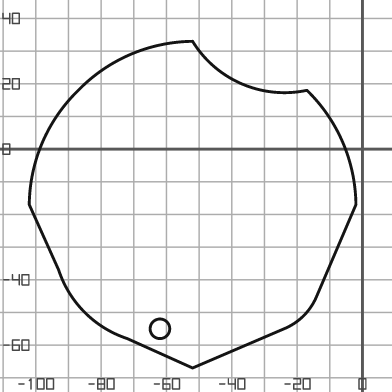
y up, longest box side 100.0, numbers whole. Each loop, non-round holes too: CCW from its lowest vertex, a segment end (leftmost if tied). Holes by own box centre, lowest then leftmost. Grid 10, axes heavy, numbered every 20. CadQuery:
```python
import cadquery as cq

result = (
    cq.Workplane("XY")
    .moveTo(-52.0, -67.0)
    .lineTo(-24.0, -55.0)
    .threePointArc((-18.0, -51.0), (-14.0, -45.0))
    .lineTo(-2.0, -17.0)
    .threePointArc((-6.0, 2.0), (-17.0, 18.0))
    .threePointArc((-37.0, 20.0), (-52.0, 33.0))
    .threePointArc((-71.0, 29.0), (-87.0, 18.0))
    .threePointArc((-98.0, 2.0), (-102.0, -17.0))
    .lineTo(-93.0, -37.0)
    .threePointArc((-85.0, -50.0), (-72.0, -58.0))
    .close()
    .moveTo(-62.0, -55.0)
    .circle(3.0)
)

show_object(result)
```